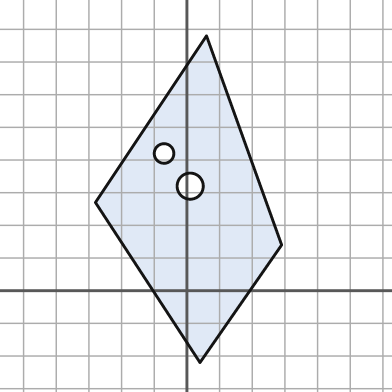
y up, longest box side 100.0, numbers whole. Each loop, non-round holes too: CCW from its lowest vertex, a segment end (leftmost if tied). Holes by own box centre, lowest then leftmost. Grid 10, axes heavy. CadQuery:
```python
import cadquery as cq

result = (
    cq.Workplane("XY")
    .moveTo(4.0, -22.0)
    .lineTo(29.0, 14.0)
    .lineTo(6.0, 78.0)
    .lineTo(-28.0, 27.0)
    .close()
    .moveTo(1.0, 32.0)
    .circle(4.0)
    .moveTo(-7.0, 42.0)
    .circle(3.0)
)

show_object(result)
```